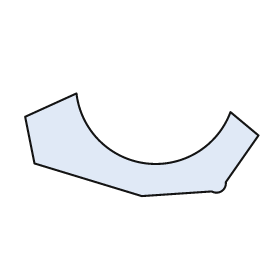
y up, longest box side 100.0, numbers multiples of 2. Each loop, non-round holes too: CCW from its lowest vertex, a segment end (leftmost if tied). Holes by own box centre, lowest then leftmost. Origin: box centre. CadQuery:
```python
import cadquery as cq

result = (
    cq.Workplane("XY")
    .moveTo(0.0, -22.0)
    .lineTo(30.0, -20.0)
    .threePointArc((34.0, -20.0), (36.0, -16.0))
    .lineTo(50.0, 4.0)
    .lineTo(38.0, 14.0)
    .threePointArc((2.0, -8.0), (-28.0, 22.0))
    .lineTo(-50.0, 12.0)
    .lineTo(-46.0, -8.0)
    .close()
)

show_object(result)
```